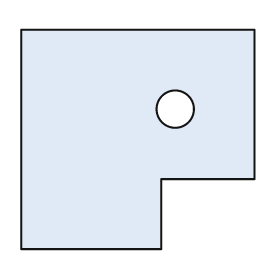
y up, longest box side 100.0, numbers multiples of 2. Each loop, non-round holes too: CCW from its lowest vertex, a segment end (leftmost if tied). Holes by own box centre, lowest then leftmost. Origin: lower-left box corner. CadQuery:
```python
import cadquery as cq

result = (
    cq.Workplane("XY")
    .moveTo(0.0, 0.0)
    .lineTo(60.0, 0.0)
    .lineTo(60.0, 30.0)
    .lineTo(100.0, 30.0)
    .lineTo(100.0, 94.0)
    .lineTo(0.0, 94.0)
    .close()
    .moveTo(66.0, 60.0)
    .circle(8.0)
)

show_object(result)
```